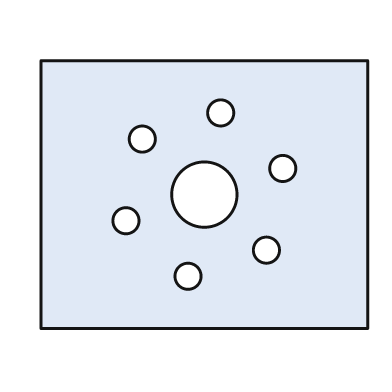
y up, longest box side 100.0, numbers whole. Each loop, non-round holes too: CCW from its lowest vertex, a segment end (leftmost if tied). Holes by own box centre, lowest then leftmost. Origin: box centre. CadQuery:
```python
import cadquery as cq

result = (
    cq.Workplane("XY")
    .moveTo(-50.0, -41.0)
    .lineTo(50.0, -41.0)
    .lineTo(50.0, 41.0)
    .lineTo(-50.0, 41.0)
    .close()
    .moveTo(-5.0, -25.0)
    .circle(4.0)
    .moveTo(19.0, -17.0)
    .circle(4.0)
    .moveTo(-24.0, -8.0)
    .circle(4.0)
    .moveTo(0.0, 0.0)
    .circle(10.0)
    .moveTo(24.0, 8.0)
    .circle(4.0)
    .moveTo(-19.0, 17.0)
    .circle(4.0)
    .moveTo(5.0, 25.0)
    .circle(4.0)
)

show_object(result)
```